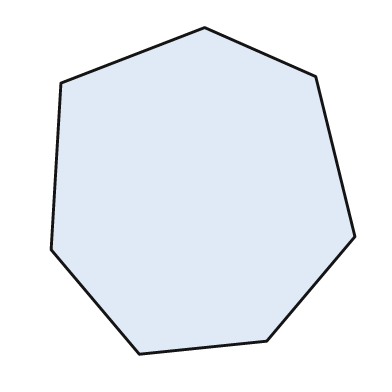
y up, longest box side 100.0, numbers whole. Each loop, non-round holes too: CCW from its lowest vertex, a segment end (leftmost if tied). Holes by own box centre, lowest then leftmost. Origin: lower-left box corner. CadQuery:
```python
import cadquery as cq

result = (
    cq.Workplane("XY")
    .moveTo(27.0, 0.0)
    .lineTo(66.0, 4.0)
    .lineTo(93.0, 36.0)
    .lineTo(81.0, 85.0)
    .lineTo(47.0, 100.0)
    .lineTo(3.0, 83.0)
    .lineTo(0.0, 32.0)
    .close()
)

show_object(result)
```